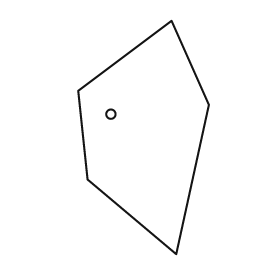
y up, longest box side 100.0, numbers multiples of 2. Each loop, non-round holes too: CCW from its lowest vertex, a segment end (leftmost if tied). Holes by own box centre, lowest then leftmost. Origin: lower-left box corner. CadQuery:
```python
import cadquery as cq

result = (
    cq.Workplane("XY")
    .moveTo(42.0, 0.0)
    .lineTo(56.0, 64.0)
    .lineTo(40.0, 100.0)
    .lineTo(0.0, 70.0)
    .lineTo(4.0, 32.0)
    .close()
    .moveTo(14.0, 60.0)
    .circle(2.0)
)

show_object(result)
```